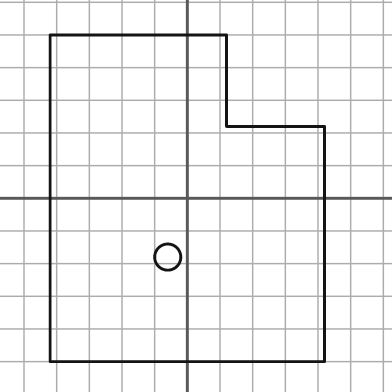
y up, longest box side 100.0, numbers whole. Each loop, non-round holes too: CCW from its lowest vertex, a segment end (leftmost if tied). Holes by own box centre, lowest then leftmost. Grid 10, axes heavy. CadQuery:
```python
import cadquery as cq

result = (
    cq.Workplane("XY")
    .moveTo(-42.0, -50.0)
    .lineTo(42.0, -50.0)
    .lineTo(42.0, 22.0)
    .lineTo(12.0, 22.0)
    .lineTo(12.0, 50.0)
    .lineTo(-42.0, 50.0)
    .close()
    .moveTo(-6.0, -18.0)
    .circle(4.0)
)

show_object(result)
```